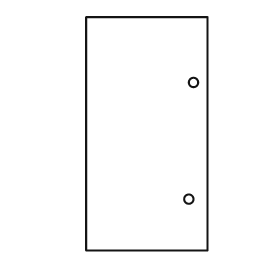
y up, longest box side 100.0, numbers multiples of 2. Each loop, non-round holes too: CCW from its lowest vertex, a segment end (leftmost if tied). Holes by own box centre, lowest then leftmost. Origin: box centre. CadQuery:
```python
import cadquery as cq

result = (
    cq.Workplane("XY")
    .moveTo(-26.0, -50.0)
    .lineTo(26.0, -50.0)
    .lineTo(26.0, 50.0)
    .lineTo(-26.0, 50.0)
    .close()
    .moveTo(18.0, -28.0)
    .circle(2.0)
    .moveTo(20.0, 22.0)
    .circle(2.0)
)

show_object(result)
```